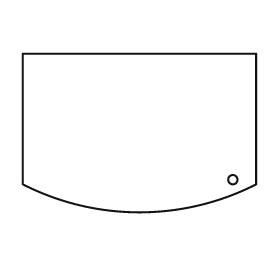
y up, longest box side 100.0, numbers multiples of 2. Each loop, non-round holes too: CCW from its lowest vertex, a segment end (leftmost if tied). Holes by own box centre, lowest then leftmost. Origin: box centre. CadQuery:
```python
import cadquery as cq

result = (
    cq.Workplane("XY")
    .moveTo(-50.0, -22.0)
    .threePointArc((0.0, -34.0), (50.0, -22.0))
    .lineTo(50.0, 34.0)
    .lineTo(-50.0, 34.0)
    .close()
    .moveTo(40.0, -20.0)
    .circle(2.0)
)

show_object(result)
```